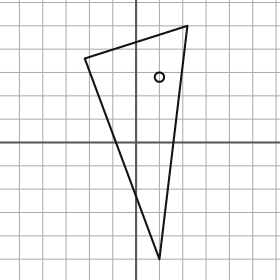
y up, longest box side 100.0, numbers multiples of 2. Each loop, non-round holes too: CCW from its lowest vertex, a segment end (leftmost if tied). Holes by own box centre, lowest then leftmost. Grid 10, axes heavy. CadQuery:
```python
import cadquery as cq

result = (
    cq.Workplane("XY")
    .moveTo(10.0, -50.0)
    .lineTo(22.0, 50.0)
    .lineTo(-22.0, 36.0)
    .close()
    .moveTo(10.0, 28.0)
    .circle(2.0)
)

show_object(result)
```